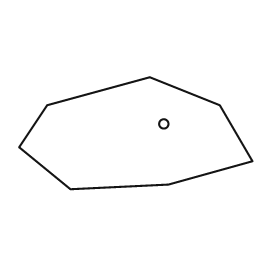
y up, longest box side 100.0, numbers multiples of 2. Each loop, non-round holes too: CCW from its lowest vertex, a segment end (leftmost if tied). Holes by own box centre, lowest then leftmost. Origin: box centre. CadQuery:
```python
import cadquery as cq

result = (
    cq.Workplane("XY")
    .moveTo(-28.0, -24.0)
    .lineTo(14.0, -22.0)
    .lineTo(50.0, -12.0)
    .lineTo(36.0, 12.0)
    .lineTo(6.0, 24.0)
    .lineTo(-38.0, 12.0)
    .lineTo(-50.0, -6.0)
    .close()
    .moveTo(12.0, 4.0)
    .circle(2.0)
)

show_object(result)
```